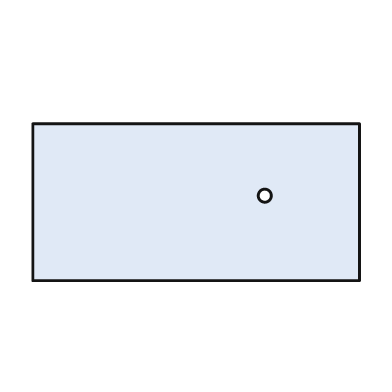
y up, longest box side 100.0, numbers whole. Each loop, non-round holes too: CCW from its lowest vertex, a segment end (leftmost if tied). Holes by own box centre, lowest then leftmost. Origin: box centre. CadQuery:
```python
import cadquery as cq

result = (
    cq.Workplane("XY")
    .moveTo(-50.0, -24.0)
    .lineTo(50.0, -24.0)
    .lineTo(50.0, 24.0)
    .lineTo(-50.0, 24.0)
    .close()
    .moveTo(21.0, 2.0)
    .circle(2.0)
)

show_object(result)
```